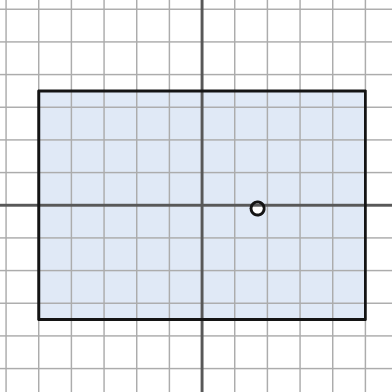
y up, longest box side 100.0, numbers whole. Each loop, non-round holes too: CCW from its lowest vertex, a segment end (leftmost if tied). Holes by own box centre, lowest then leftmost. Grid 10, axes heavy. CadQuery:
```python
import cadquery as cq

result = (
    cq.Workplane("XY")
    .moveTo(-50.0, -35.0)
    .lineTo(50.0, -35.0)
    .lineTo(50.0, 35.0)
    .lineTo(-50.0, 35.0)
    .close()
    .moveTo(17.0, -1.0)
    .circle(2.0)
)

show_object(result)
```